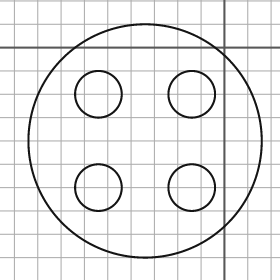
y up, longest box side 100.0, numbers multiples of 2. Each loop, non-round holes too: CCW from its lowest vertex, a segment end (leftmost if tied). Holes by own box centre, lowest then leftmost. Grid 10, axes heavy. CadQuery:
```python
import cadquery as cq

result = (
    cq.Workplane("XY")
    .moveTo(-34.0, -40.0)
    .circle(50.0)
    .moveTo(-54.0, -60.0)
    .circle(10.0)
    .moveTo(-14.0, -60.0)
    .circle(10.0)
    .moveTo(-54.0, -20.0)
    .circle(10.0)
    .moveTo(-14.0, -20.0)
    .circle(10.0)
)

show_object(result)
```